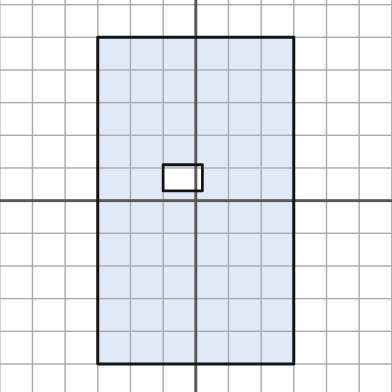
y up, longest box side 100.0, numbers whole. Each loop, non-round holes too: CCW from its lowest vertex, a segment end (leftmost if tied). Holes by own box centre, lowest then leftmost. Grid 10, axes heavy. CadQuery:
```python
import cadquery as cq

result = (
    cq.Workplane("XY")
    .moveTo(-30.0, -50.0)
    .lineTo(30.0, -50.0)
    .lineTo(30.0, 50.0)
    .lineTo(-30.0, 50.0)
    .close()
    .moveTo(-10.0, 3.0)
    .lineTo(2.0, 3.0)
    .lineTo(2.0, 11.0)
    .lineTo(-10.0, 11.0)
    .close()
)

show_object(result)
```